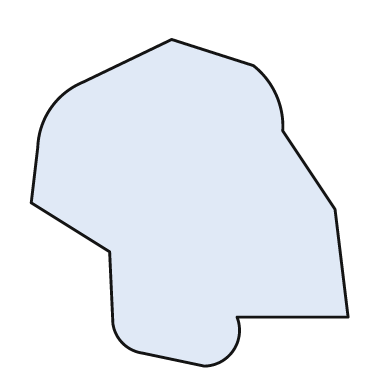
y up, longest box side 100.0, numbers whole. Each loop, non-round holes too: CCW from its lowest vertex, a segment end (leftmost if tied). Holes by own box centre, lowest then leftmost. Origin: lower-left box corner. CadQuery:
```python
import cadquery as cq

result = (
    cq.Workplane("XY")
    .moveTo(53.0, 0.0)
    .threePointArc((62.0, 5.0), (63.0, 15.0))
    .lineTo(97.0, 15.0)
    .lineTo(93.0, 48.0)
    .lineTo(77.0, 72.0)
    .threePointArc((75.0, 83.0), (68.0, 92.0))
    .lineTo(43.0, 100.0)
    .lineTo(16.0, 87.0)
    .threePointArc((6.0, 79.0), (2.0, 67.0))
    .lineTo(0.0, 50.0)
    .lineTo(24.0, 35.0)
    .lineTo(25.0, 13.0)
    .threePointArc((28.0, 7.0), (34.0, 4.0))
    .close()
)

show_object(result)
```